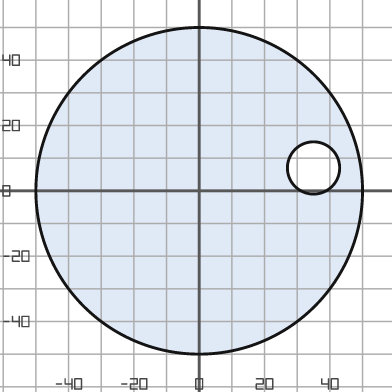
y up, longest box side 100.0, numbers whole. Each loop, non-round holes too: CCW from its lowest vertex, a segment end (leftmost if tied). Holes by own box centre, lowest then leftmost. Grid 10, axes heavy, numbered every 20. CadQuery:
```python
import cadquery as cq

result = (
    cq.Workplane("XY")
    .moveTo(0.0, 0.0)
    .circle(50.0)
    .moveTo(35.0, 7.0)
    .circle(8.0)
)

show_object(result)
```